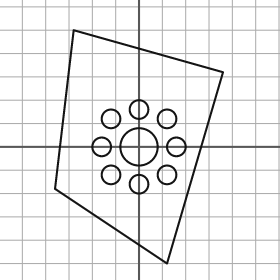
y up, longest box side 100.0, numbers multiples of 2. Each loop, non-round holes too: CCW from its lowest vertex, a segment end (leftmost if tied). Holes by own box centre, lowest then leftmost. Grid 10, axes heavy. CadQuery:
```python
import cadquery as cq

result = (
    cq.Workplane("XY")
    .moveTo(12.0, -50.0)
    .lineTo(36.0, 32.0)
    .lineTo(-28.0, 50.0)
    .lineTo(-36.0, -18.0)
    .close()
    .moveTo(0.0, -16.0)
    .circle(4.0)
    .moveTo(-12.0, -12.0)
    .circle(4.0)
    .moveTo(12.0, -12.0)
    .circle(4.0)
    .moveTo(-16.0, 0.0)
    .circle(4.0)
    .moveTo(0.0, 0.0)
    .circle(8.0)
    .moveTo(16.0, 0.0)
    .circle(4.0)
    .moveTo(-12.0, 12.0)
    .circle(4.0)
    .moveTo(12.0, 12.0)
    .circle(4.0)
    .moveTo(0.0, 16.0)
    .circle(4.0)
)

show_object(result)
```